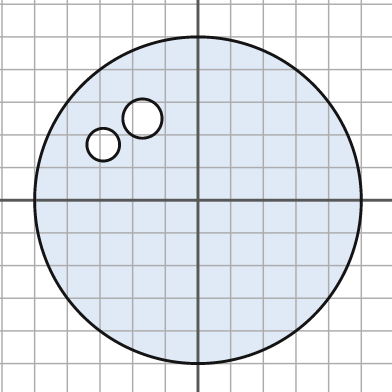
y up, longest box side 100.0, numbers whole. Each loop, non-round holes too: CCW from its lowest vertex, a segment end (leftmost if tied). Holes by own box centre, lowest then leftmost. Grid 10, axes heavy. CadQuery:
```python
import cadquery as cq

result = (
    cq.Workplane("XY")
    .moveTo(0.0, 0.0)
    .circle(50.0)
    .moveTo(-29.0, 17.0)
    .circle(5.0)
    .moveTo(-17.0, 25.0)
    .circle(6.0)
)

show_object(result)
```